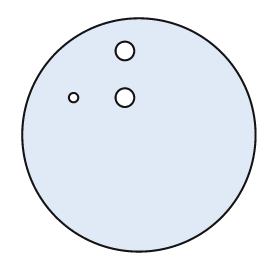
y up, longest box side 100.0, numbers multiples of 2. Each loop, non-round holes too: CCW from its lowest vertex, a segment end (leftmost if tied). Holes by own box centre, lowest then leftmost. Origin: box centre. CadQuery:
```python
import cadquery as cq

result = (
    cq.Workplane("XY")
    .moveTo(0.0, 0.0)
    .circle(50.0)
    .moveTo(-28.0, 16.0)
    .circle(2.0)
    .moveTo(-6.0, 16.0)
    .circle(4.0)
    .moveTo(-6.0, 36.0)
    .circle(4.0)
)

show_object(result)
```